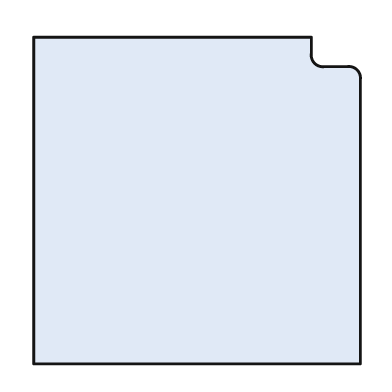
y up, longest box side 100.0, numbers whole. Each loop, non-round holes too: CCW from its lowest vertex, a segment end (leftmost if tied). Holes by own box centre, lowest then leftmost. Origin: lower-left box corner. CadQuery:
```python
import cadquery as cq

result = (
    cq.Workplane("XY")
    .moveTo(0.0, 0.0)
    .lineTo(100.0, 0.0)
    .lineTo(100.0, 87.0)
    .threePointArc((99.0, 90.0), (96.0, 91.0))
    .lineTo(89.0, 91.0)
    .threePointArc((86.0, 92.0), (85.0, 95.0))
    .lineTo(85.0, 100.0)
    .lineTo(0.0, 100.0)
    .close()
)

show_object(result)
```